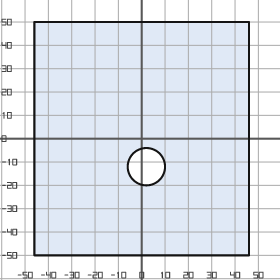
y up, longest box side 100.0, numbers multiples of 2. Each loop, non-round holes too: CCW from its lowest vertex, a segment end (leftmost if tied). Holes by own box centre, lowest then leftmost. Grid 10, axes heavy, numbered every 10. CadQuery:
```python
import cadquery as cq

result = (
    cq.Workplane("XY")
    .moveTo(-46.0, -50.0)
    .lineTo(46.0, -50.0)
    .lineTo(46.0, 50.0)
    .lineTo(-46.0, 50.0)
    .close()
    .moveTo(2.0, -12.0)
    .circle(8.0)
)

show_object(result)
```